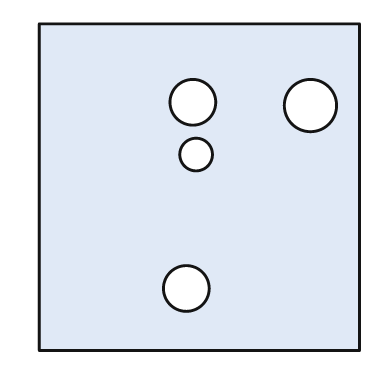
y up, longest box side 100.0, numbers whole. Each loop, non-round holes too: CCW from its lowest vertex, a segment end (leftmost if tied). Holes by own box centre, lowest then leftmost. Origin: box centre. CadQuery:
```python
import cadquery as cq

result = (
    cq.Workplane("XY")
    .moveTo(-49.0, -50.0)
    .lineTo(49.0, -50.0)
    .lineTo(49.0, 50.0)
    .lineTo(-49.0, 50.0)
    .close()
    .moveTo(-4.0, -31.0)
    .circle(7.0)
    .moveTo(-1.0, 10.0)
    .circle(5.0)
    .moveTo(34.0, 25.0)
    .circle(8.0)
    .moveTo(-2.0, 26.0)
    .circle(7.0)
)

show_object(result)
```